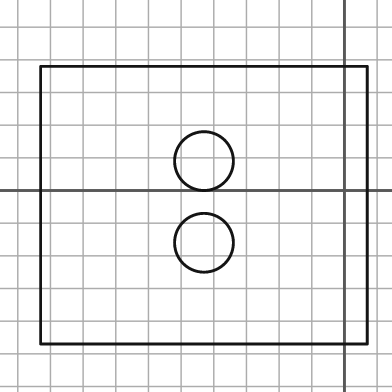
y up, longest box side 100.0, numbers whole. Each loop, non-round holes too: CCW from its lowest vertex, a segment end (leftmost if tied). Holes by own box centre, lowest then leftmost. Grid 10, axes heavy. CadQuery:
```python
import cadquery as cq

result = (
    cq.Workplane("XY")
    .moveTo(-93.0, -47.0)
    .lineTo(7.0, -47.0)
    .lineTo(7.0, 38.0)
    .lineTo(-93.0, 38.0)
    .close()
    .moveTo(-43.0, -16.0)
    .circle(9.0)
    .moveTo(-43.0, 9.0)
    .circle(9.0)
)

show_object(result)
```